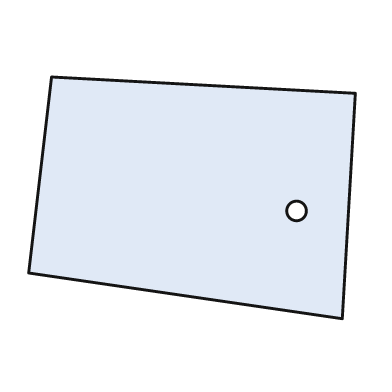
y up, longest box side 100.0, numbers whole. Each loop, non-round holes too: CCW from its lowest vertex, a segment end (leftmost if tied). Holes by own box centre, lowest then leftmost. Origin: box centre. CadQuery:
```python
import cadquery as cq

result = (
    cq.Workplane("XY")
    .moveTo(46.0, -37.0)
    .lineTo(50.0, 32.0)
    .lineTo(-43.0, 37.0)
    .lineTo(-50.0, -23.0)
    .close()
    .moveTo(32.0, -4.0)
    .circle(3.0)
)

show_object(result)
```